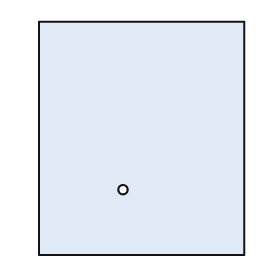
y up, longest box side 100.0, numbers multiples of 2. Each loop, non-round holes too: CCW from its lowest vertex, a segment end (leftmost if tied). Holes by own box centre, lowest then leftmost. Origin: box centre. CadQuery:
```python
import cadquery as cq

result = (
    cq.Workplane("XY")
    .moveTo(-44.0, -50.0)
    .lineTo(44.0, -50.0)
    .lineTo(44.0, 50.0)
    .lineTo(-44.0, 50.0)
    .close()
    .moveTo(-8.0, -22.0)
    .circle(2.0)
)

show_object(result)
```